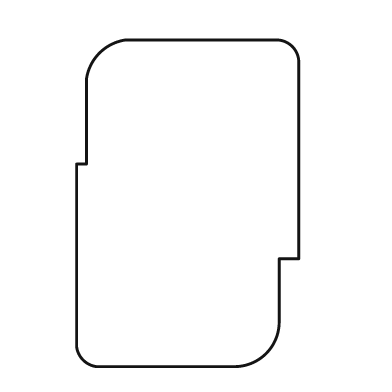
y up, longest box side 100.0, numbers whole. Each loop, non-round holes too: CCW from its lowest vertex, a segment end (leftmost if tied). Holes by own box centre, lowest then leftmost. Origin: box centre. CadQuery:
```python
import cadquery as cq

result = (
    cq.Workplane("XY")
    .moveTo(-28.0, -50.0)
    .lineTo(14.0, -50.0)
    .threePointArc((24.0, -46.0), (28.0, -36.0))
    .lineTo(28.0, -17.0)
    .lineTo(34.0, -17.0)
    .lineTo(34.0, 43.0)
    .threePointArc((32.0, 48.0), (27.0, 50.0))
    .lineTo(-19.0, 50.0)
    .threePointArc((-27.0, 46.0), (-31.0, 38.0))
    .lineTo(-31.0, 12.0)
    .lineTo(-34.0, 12.0)
    .lineTo(-34.0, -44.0)
    .threePointArc((-32.0, -48.0), (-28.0, -50.0))
    .close()
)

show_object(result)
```